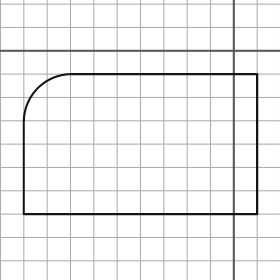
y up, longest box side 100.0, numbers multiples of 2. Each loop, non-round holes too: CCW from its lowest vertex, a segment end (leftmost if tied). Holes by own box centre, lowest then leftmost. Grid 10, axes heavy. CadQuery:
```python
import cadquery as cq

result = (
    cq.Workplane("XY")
    .moveTo(-90.0, -70.0)
    .lineTo(10.0, -70.0)
    .lineTo(10.0, -10.0)
    .lineTo(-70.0, -10.0)
    .threePointArc((-84.0, -16.0), (-90.0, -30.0))
    .close()
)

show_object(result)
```